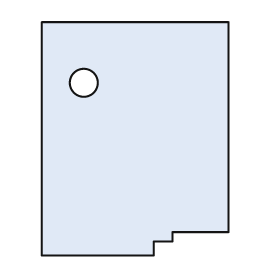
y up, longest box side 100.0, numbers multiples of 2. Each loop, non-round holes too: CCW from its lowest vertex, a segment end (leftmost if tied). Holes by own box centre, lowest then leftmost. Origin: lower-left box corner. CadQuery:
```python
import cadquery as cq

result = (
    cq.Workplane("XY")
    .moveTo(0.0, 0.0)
    .lineTo(48.0, 0.0)
    .lineTo(48.0, 6.0)
    .lineTo(56.0, 6.0)
    .lineTo(56.0, 10.0)
    .lineTo(80.0, 10.0)
    .lineTo(80.0, 100.0)
    .lineTo(0.0, 100.0)
    .close()
    .moveTo(18.0, 74.0)
    .circle(6.0)
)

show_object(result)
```